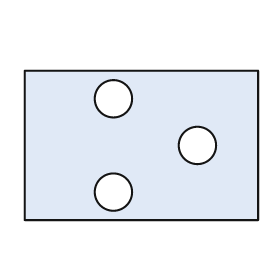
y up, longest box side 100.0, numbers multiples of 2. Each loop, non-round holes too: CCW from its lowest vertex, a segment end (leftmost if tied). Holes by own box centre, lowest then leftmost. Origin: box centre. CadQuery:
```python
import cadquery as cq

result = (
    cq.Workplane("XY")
    .moveTo(-50.0, -32.0)
    .lineTo(50.0, -32.0)
    .lineTo(50.0, 32.0)
    .lineTo(-50.0, 32.0)
    .close()
    .moveTo(-12.0, -20.0)
    .circle(8.0)
    .moveTo(24.0, 0.0)
    .circle(8.0)
    .moveTo(-12.0, 20.0)
    .circle(8.0)
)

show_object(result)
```